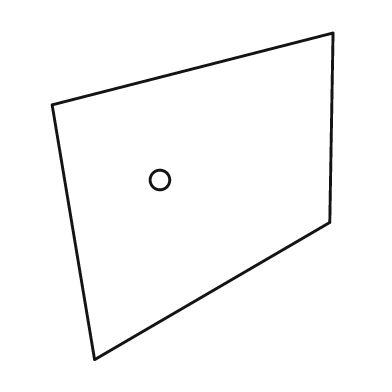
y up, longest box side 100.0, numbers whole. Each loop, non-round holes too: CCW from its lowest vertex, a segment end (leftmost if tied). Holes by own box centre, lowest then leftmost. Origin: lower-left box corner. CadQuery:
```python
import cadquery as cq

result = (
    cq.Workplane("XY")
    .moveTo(13.0, 0.0)
    .lineTo(85.0, 42.0)
    .lineTo(86.0, 100.0)
    .lineTo(0.0, 78.0)
    .close()
    .moveTo(33.0, 55.0)
    .circle(3.0)
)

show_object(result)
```